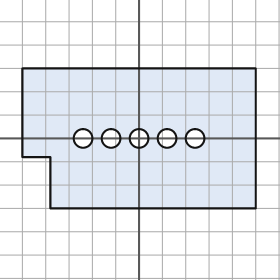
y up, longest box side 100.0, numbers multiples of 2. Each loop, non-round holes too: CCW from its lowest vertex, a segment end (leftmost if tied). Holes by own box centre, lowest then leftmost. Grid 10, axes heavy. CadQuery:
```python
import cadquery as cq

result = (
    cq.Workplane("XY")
    .moveTo(-38.0, -30.0)
    .lineTo(50.0, -30.0)
    .lineTo(50.0, 30.0)
    .lineTo(-50.0, 30.0)
    .lineTo(-50.0, -8.0)
    .lineTo(-38.0, -8.0)
    .close()
    .moveTo(-24.0, 0.0)
    .circle(4.0)
    .moveTo(-12.0, 0.0)
    .circle(4.0)
    .moveTo(0.0, 0.0)
    .circle(4.0)
    .moveTo(12.0, 0.0)
    .circle(4.0)
    .moveTo(24.0, 0.0)
    .circle(4.0)
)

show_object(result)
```